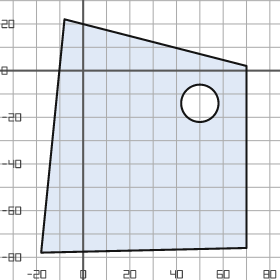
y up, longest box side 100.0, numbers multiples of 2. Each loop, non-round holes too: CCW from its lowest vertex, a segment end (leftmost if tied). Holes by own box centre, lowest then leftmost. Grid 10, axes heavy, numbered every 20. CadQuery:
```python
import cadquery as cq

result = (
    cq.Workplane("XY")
    .moveTo(-18.0, -78.0)
    .lineTo(70.0, -76.0)
    .lineTo(70.0, 2.0)
    .lineTo(-8.0, 22.0)
    .close()
    .moveTo(50.0, -14.0)
    .circle(8.0)
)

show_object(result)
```